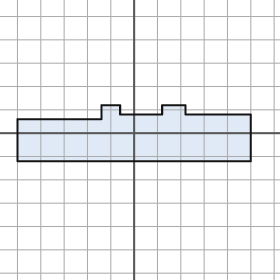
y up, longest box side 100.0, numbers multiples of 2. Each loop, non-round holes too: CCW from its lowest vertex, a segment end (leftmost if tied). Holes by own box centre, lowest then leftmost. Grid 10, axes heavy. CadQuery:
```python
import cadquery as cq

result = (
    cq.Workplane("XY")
    .moveTo(-50.0, -12.0)
    .lineTo(50.0, -12.0)
    .lineTo(50.0, 8.0)
    .lineTo(22.0, 8.0)
    .lineTo(22.0, 12.0)
    .lineTo(12.0, 12.0)
    .lineTo(12.0, 8.0)
    .lineTo(-6.0, 8.0)
    .lineTo(-6.0, 12.0)
    .lineTo(-14.0, 12.0)
    .lineTo(-14.0, 6.0)
    .lineTo(-50.0, 6.0)
    .close()
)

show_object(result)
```